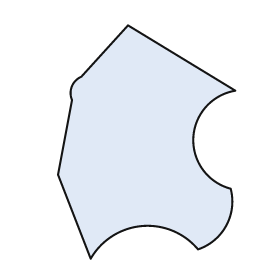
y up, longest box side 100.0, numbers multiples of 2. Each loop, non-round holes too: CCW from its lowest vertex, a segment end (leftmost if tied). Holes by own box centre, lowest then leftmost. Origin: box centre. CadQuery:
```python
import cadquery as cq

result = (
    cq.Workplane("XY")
    .moveTo(-24.0, -50.0)
    .threePointArc((-2.0, -36.0), (22.0, -46.0))
    .threePointArc((34.0, -36.0), (36.0, -20.0))
    .threePointArc((20.0, 2.0), (38.0, 22.0))
    .lineTo(-8.0, 50.0)
    .lineTo(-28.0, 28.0)
    .threePointArc((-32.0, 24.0), (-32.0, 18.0))
    .lineTo(-38.0, -14.0)
    .close()
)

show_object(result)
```